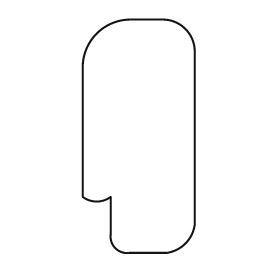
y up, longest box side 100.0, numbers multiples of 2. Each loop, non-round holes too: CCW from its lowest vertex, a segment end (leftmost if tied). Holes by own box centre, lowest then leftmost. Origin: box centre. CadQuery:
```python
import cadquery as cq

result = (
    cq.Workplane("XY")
    .moveTo(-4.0, -50.0)
    .lineTo(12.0, -50.0)
    .threePointArc((20.0, -46.0), (24.0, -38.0))
    .lineTo(24.0, 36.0)
    .threePointArc((20.0, 46.0), (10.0, 50.0))
    .lineTo(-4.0, 50.0)
    .threePointArc((-18.0, 44.0), (-24.0, 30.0))
    .lineTo(-24.0, -26.0)
    .threePointArc((-18.0, -28.0), (-12.0, -26.0))
    .lineTo(-12.0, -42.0)
    .threePointArc((-10.0, -48.0), (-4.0, -50.0))
    .close()
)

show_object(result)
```